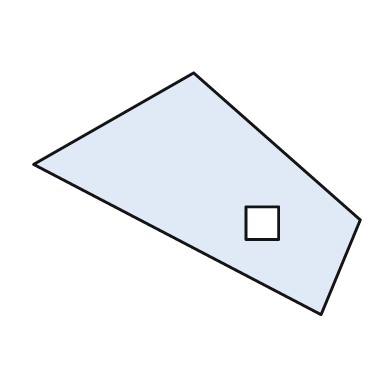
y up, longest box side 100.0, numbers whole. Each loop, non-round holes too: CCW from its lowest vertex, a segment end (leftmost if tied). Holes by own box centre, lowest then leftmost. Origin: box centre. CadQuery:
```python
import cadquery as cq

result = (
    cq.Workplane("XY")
    .moveTo(38.0, -37.0)
    .lineTo(50.0, -8.0)
    .lineTo(-1.0, 37.0)
    .lineTo(-50.0, 9.0)
    .close()
    .moveTo(15.0, -14.0)
    .lineTo(25.0, -14.0)
    .lineTo(25.0, -4.0)
    .lineTo(15.0, -4.0)
    .close()
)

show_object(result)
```